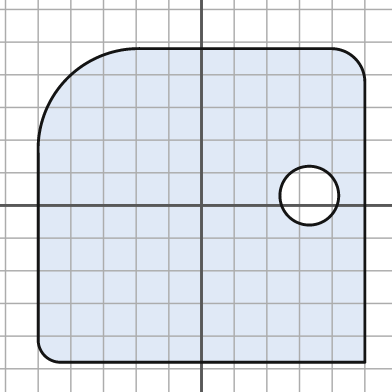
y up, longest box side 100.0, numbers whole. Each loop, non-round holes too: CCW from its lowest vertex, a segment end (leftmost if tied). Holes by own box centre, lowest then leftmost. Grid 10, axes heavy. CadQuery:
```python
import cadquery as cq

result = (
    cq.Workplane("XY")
    .moveTo(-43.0, -48.0)
    .lineTo(50.0, -48.0)
    .lineTo(50.0, 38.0)
    .threePointArc((47.0, 45.0), (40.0, 48.0))
    .lineTo(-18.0, 48.0)
    .threePointArc((-41.0, 39.0), (-50.0, 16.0))
    .lineTo(-50.0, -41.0)
    .threePointArc((-48.0, -46.0), (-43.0, -48.0))
    .close()
    .moveTo(33.0, 3.0)
    .circle(9.0)
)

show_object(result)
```